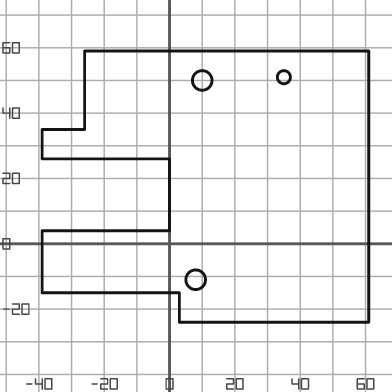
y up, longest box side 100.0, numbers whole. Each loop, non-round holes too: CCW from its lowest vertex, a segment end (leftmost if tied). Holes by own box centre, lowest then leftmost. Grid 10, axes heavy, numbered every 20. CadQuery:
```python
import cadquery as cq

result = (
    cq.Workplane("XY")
    .moveTo(3.0, -24.0)
    .lineTo(61.0, -24.0)
    .lineTo(61.0, 59.0)
    .lineTo(-26.0, 59.0)
    .lineTo(-26.0, 35.0)
    .lineTo(-39.0, 35.0)
    .lineTo(-39.0, 26.0)
    .lineTo(0.0, 26.0)
    .lineTo(0.0, 4.0)
    .lineTo(-39.0, 4.0)
    .lineTo(-39.0, -15.0)
    .lineTo(3.0, -15.0)
    .close()
    .moveTo(8.0, -11.0)
    .circle(3.0)
    .moveTo(10.0, 50.0)
    .circle(3.0)
    .moveTo(35.0, 51.0)
    .circle(2.0)
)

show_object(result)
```